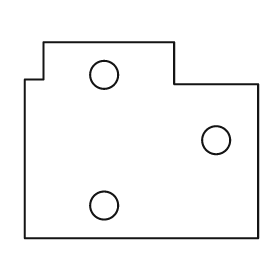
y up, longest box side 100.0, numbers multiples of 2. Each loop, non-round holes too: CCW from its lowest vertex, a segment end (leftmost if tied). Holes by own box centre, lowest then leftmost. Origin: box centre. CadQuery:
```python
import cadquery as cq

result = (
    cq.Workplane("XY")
    .moveTo(-50.0, -42.0)
    .lineTo(50.0, -42.0)
    .lineTo(50.0, 24.0)
    .lineTo(14.0, 24.0)
    .lineTo(14.0, 42.0)
    .lineTo(-42.0, 42.0)
    .lineTo(-42.0, 26.0)
    .lineTo(-50.0, 26.0)
    .close()
    .moveTo(-16.0, -28.0)
    .circle(6.0)
    .moveTo(32.0, 0.0)
    .circle(6.0)
    .moveTo(-16.0, 28.0)
    .circle(6.0)
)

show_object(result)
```